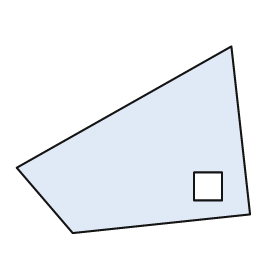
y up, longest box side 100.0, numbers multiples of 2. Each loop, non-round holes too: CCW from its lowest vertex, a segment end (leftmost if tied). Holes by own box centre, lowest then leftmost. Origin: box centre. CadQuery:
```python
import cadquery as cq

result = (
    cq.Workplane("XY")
    .moveTo(-26.0, -40.0)
    .lineTo(50.0, -32.0)
    .lineTo(42.0, 40.0)
    .lineTo(-50.0, -12.0)
    .close()
    .moveTo(26.0, -26.0)
    .lineTo(38.0, -26.0)
    .lineTo(38.0, -14.0)
    .lineTo(26.0, -14.0)
    .close()
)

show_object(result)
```